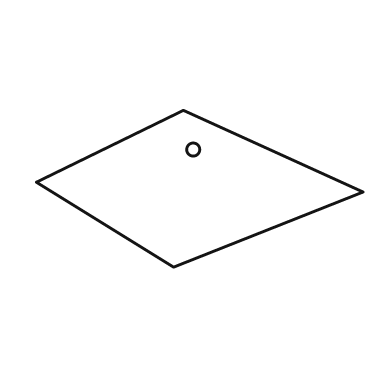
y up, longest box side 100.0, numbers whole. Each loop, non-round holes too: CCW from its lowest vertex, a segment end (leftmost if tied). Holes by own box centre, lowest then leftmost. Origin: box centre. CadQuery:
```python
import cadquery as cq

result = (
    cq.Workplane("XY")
    .moveTo(-8.0, -24.0)
    .lineTo(50.0, -1.0)
    .lineTo(-5.0, 24.0)
    .lineTo(-50.0, 2.0)
    .close()
    .moveTo(-2.0, 12.0)
    .circle(2.0)
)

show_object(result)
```